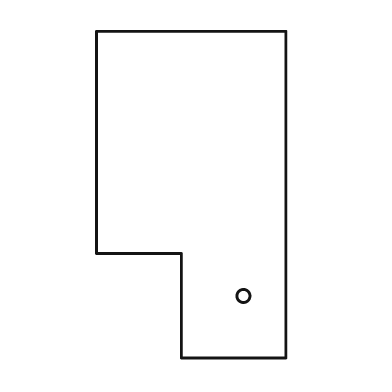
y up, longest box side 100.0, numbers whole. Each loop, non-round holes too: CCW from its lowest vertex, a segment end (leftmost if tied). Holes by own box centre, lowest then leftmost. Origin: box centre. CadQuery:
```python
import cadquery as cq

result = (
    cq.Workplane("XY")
    .moveTo(-3.0, -50.0)
    .lineTo(29.0, -50.0)
    .lineTo(29.0, 50.0)
    .lineTo(-29.0, 50.0)
    .lineTo(-29.0, -18.0)
    .lineTo(-3.0, -18.0)
    .close()
    .moveTo(16.0, -31.0)
    .circle(2.0)
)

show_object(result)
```